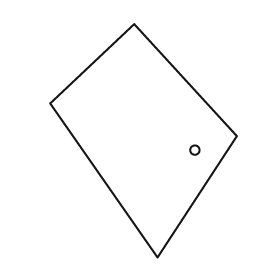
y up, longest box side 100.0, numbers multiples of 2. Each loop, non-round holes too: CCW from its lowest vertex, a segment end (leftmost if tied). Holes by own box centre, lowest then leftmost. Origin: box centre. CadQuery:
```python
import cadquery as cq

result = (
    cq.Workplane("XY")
    .moveTo(6.0, -50.0)
    .lineTo(40.0, 2.0)
    .lineTo(-4.0, 50.0)
    .lineTo(-40.0, 16.0)
    .close()
    .moveTo(22.0, -4.0)
    .circle(2.0)
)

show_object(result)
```